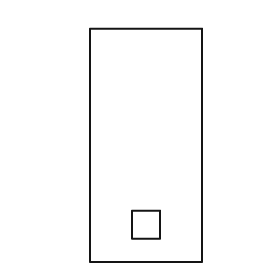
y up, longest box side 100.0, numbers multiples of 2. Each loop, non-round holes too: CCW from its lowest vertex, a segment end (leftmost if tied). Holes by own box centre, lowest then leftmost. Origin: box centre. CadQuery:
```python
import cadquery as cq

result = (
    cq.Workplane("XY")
    .moveTo(-24.0, -50.0)
    .lineTo(24.0, -50.0)
    .lineTo(24.0, 50.0)
    .lineTo(-24.0, 50.0)
    .close()
    .moveTo(-6.0, -40.0)
    .lineTo(6.0, -40.0)
    .lineTo(6.0, -28.0)
    .lineTo(-6.0, -28.0)
    .close()
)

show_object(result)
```